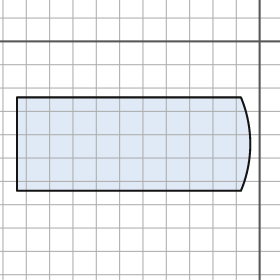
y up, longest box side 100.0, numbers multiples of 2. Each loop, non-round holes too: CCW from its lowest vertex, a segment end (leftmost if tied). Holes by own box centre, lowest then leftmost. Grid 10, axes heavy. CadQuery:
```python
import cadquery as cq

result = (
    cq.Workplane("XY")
    .moveTo(-104.0, -64.0)
    .lineTo(-8.0, -64.0)
    .threePointArc((-4.0, -44.0), (-8.0, -24.0))
    .lineTo(-104.0, -24.0)
    .close()
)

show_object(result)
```